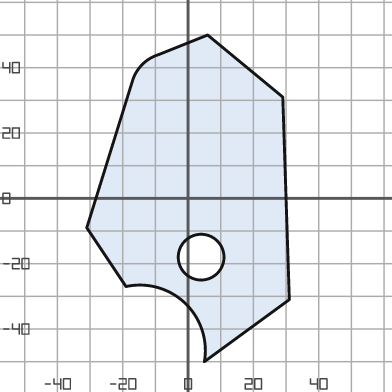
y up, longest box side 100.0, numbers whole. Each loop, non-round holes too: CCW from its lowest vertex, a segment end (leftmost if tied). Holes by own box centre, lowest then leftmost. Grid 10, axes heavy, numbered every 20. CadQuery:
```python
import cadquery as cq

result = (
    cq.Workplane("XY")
    .moveTo(5.0, -50.0)
    .lineTo(31.0, -31.0)
    .lineTo(29.0, 31.0)
    .lineTo(6.0, 50.0)
    .lineTo(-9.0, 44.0)
    .threePointArc((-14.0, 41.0), (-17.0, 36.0))
    .lineTo(-31.0, -9.0)
    .lineTo(-19.0, -27.0)
    .threePointArc((-1.0, -32.0), (5.0, -50.0))
    .close()
    .moveTo(4.0, -18.0)
    .circle(7.0)
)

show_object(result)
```